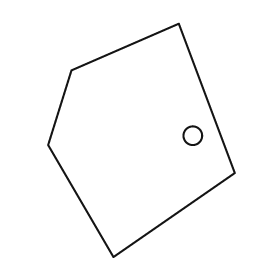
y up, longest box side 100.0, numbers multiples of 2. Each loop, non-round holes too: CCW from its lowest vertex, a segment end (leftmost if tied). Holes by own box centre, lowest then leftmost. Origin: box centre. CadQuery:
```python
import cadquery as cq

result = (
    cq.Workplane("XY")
    .moveTo(-12.0, -50.0)
    .lineTo(40.0, -14.0)
    .lineTo(16.0, 50.0)
    .lineTo(-30.0, 30.0)
    .lineTo(-40.0, -2.0)
    .close()
    .moveTo(22.0, 2.0)
    .circle(4.0)
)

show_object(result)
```